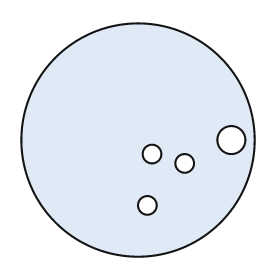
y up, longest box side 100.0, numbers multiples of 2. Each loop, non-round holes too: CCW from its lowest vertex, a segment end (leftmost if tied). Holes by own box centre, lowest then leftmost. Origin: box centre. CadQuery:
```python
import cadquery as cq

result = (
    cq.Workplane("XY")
    .moveTo(0.0, 0.0)
    .circle(50.0)
    .moveTo(4.0, -28.0)
    .circle(4.0)
    .moveTo(20.0, -10.0)
    .circle(4.0)
    .moveTo(6.0, -6.0)
    .circle(4.0)
    .moveTo(40.0, 0.0)
    .circle(6.0)
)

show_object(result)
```